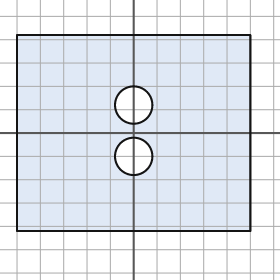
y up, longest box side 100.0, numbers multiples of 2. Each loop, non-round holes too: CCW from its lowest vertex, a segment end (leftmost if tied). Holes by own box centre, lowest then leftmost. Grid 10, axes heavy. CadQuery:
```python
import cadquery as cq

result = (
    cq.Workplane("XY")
    .moveTo(-50.0, -42.0)
    .lineTo(50.0, -42.0)
    .lineTo(50.0, 42.0)
    .lineTo(-50.0, 42.0)
    .close()
    .moveTo(0.0, -10.0)
    .circle(8.0)
    .moveTo(0.0, 12.0)
    .circle(8.0)
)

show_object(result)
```